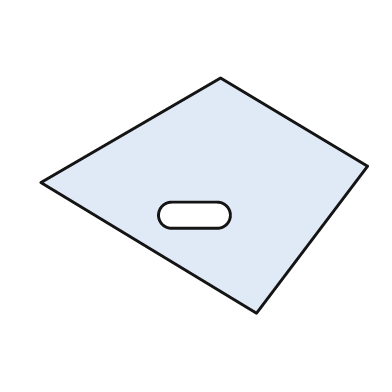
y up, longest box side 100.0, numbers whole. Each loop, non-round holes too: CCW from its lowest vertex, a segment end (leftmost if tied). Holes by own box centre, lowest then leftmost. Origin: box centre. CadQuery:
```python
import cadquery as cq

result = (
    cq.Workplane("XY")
    .moveTo(16.0, -36.0)
    .lineTo(50.0, 9.0)
    .lineTo(5.0, 36.0)
    .lineTo(-50.0, 4.0)
    .close()
    .moveTo(-10.0, -10.0)
    .lineTo(4.0, -10.0)
    .threePointArc((8.0, -6.0), (4.0, -2.0))
    .lineTo(-10.0, -2.0)
    .threePointArc((-14.0, -6.0), (-10.0, -10.0))
    .close()
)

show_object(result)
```